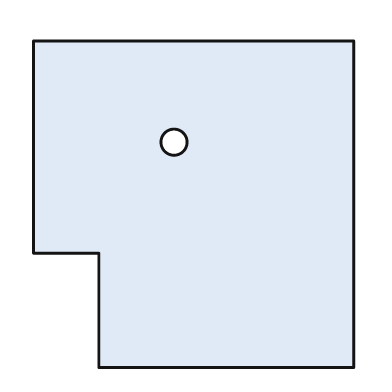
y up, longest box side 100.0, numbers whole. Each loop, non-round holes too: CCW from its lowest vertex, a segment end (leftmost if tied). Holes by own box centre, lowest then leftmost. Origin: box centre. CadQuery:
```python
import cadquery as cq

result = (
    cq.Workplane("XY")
    .moveTo(-29.0, -50.0)
    .lineTo(49.0, -50.0)
    .lineTo(49.0, 50.0)
    .lineTo(-49.0, 50.0)
    .lineTo(-49.0, -15.0)
    .lineTo(-29.0, -15.0)
    .close()
    .moveTo(-6.0, 19.0)
    .circle(4.0)
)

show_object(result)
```